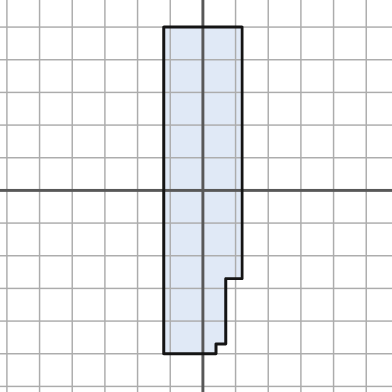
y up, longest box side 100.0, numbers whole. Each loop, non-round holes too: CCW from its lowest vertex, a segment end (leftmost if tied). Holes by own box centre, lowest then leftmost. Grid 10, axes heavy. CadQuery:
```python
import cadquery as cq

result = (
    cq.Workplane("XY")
    .moveTo(-12.0, -50.0)
    .lineTo(4.0, -50.0)
    .lineTo(4.0, -47.0)
    .lineTo(7.0, -47.0)
    .lineTo(7.0, -27.0)
    .lineTo(12.0, -27.0)
    .lineTo(12.0, 50.0)
    .lineTo(-12.0, 50.0)
    .close()
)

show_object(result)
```